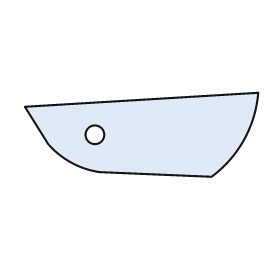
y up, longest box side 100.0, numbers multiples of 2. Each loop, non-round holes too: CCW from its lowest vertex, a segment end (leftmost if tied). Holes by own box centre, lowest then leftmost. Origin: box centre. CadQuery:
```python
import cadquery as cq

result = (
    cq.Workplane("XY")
    .moveTo(30.0, -18.0)
    .threePointArc((44.0, -2.0), (50.0, 18.0))
    .lineTo(-50.0, 12.0)
    .lineTo(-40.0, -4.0)
    .threePointArc((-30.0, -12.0), (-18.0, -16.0))
    .close()
    .moveTo(-20.0, 0.0)
    .circle(4.0)
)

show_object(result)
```